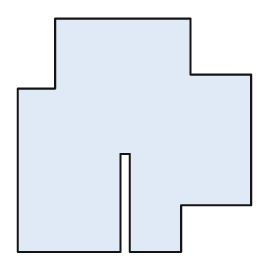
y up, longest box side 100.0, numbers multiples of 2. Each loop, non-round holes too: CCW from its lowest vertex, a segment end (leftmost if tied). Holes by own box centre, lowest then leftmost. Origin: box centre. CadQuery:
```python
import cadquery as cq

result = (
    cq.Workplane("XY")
    .moveTo(-50.0, -50.0)
    .lineTo(-6.0, -50.0)
    .lineTo(-6.0, -8.0)
    .lineTo(-2.0, -8.0)
    .lineTo(-2.0, -50.0)
    .lineTo(20.0, -50.0)
    .lineTo(20.0, -30.0)
    .lineTo(50.0, -30.0)
    .lineTo(50.0, 26.0)
    .lineTo(24.0, 26.0)
    .lineTo(24.0, 50.0)
    .lineTo(-34.0, 50.0)
    .lineTo(-34.0, 20.0)
    .lineTo(-50.0, 20.0)
    .close()
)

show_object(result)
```